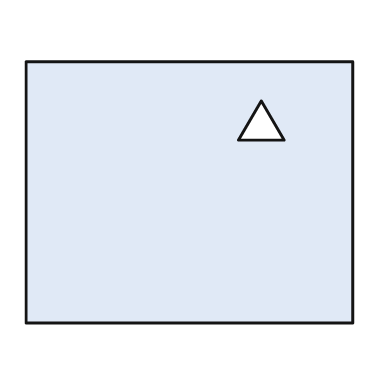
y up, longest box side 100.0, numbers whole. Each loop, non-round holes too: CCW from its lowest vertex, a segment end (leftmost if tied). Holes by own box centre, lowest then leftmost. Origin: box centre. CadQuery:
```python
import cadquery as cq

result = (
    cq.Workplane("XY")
    .moveTo(-50.0, -40.0)
    .lineTo(50.0, -40.0)
    .lineTo(50.0, 40.0)
    .lineTo(-50.0, 40.0)
    .close()
    .moveTo(15.0, 16.0)
    .lineTo(29.0, 16.0)
    .lineTo(22.0, 28.0)
    .close()
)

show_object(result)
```